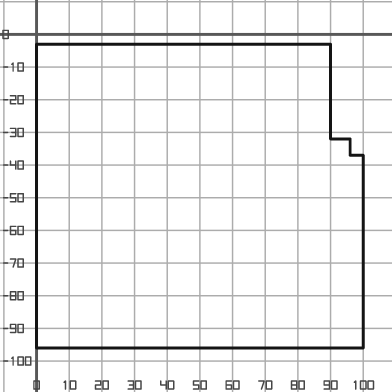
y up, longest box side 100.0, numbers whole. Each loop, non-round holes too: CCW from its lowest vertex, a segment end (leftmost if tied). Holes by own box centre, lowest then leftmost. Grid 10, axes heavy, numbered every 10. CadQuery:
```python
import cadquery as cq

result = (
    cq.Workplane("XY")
    .moveTo(0.0, -96.0)
    .lineTo(100.0, -96.0)
    .lineTo(100.0, -37.0)
    .lineTo(96.0, -37.0)
    .lineTo(96.0, -32.0)
    .lineTo(90.0, -32.0)
    .lineTo(90.0, -3.0)
    .lineTo(0.0, -3.0)
    .close()
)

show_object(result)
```